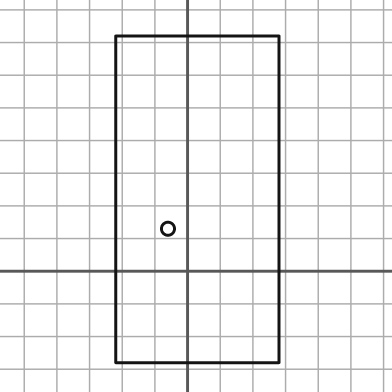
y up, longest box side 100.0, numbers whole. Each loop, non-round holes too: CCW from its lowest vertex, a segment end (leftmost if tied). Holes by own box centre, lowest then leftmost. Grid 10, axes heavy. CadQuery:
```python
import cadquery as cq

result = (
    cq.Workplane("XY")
    .moveTo(-22.0, -28.0)
    .lineTo(28.0, -28.0)
    .lineTo(28.0, 72.0)
    .lineTo(-22.0, 72.0)
    .close()
    .moveTo(-6.0, 13.0)
    .circle(2.0)
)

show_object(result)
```